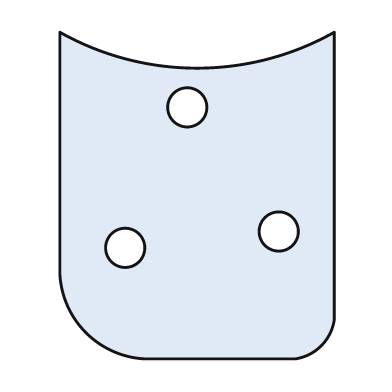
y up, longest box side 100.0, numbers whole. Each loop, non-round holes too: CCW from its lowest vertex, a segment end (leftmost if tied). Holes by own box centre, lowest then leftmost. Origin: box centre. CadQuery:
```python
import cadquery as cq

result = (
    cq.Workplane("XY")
    .moveTo(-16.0, -50.0)
    .lineTo(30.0, -50.0)
    .threePointArc((38.0, -46.0), (42.0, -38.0))
    .lineTo(42.0, 50.0)
    .threePointArc((0.0, 39.0), (-42.0, 50.0))
    .lineTo(-42.0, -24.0)
    .threePointArc((-34.0, -42.0), (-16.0, -50.0))
    .close()
    .moveTo(-22.0, -16.0)
    .circle(6.0)
    .moveTo(25.0, -11.0)
    .circle(6.0)
    .moveTo(-3.0, 27.0)
    .circle(6.0)
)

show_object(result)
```